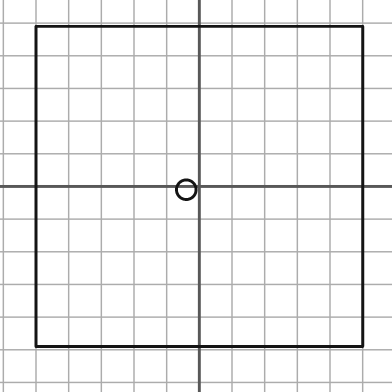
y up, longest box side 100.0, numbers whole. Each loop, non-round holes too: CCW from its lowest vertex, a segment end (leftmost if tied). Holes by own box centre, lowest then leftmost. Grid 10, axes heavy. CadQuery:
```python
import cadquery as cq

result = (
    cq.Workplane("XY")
    .moveTo(-50.0, -49.0)
    .lineTo(50.0, -49.0)
    .lineTo(50.0, 49.0)
    .lineTo(-50.0, 49.0)
    .close()
    .moveTo(-4.0, -1.0)
    .circle(3.0)
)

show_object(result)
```